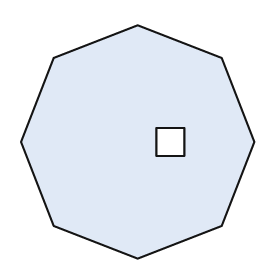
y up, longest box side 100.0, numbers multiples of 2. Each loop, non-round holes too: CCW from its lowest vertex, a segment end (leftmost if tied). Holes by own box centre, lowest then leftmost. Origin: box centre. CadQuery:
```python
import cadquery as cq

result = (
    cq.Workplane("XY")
    .moveTo(0.0, -50.0)
    .lineTo(36.0, -36.0)
    .lineTo(50.0, 0.0)
    .lineTo(36.0, 36.0)
    .lineTo(0.0, 50.0)
    .lineTo(-36.0, 36.0)
    .lineTo(-50.0, 0.0)
    .lineTo(-36.0, -36.0)
    .close()
    .moveTo(8.0, -6.0)
    .lineTo(20.0, -6.0)
    .lineTo(20.0, 6.0)
    .lineTo(8.0, 6.0)
    .close()
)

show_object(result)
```